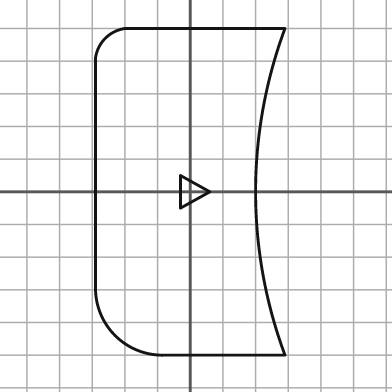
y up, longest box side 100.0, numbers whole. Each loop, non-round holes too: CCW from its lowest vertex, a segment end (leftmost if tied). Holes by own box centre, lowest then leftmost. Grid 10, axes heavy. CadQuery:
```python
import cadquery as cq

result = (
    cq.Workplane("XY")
    .moveTo(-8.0, -50.0)
    .lineTo(29.0, -50.0)
    .threePointArc((20.0, 0.0), (29.0, 50.0))
    .lineTo(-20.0, 50.0)
    .threePointArc((-26.0, 47.0), (-29.0, 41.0))
    .lineTo(-29.0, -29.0)
    .threePointArc((-23.0, -44.0), (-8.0, -50.0))
    .close()
    .moveTo(-3.0, -5.0)
    .lineTo(6.0, 0.0)
    .lineTo(-3.0, 5.0)
    .close()
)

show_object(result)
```